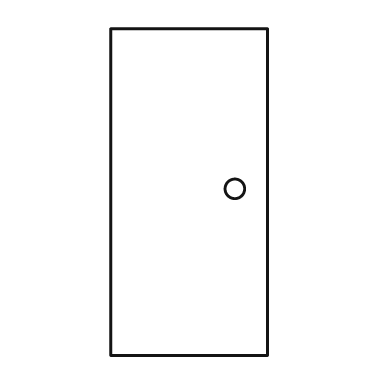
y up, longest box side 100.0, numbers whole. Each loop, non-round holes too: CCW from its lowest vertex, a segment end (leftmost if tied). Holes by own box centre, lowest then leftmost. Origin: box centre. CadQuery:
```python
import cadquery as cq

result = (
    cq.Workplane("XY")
    .moveTo(-24.0, -50.0)
    .lineTo(24.0, -50.0)
    .lineTo(24.0, 50.0)
    .lineTo(-24.0, 50.0)
    .close()
    .moveTo(14.0, 1.0)
    .circle(3.0)
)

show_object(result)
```